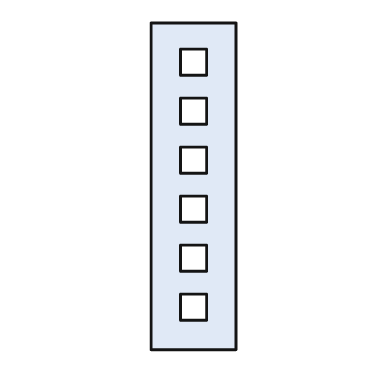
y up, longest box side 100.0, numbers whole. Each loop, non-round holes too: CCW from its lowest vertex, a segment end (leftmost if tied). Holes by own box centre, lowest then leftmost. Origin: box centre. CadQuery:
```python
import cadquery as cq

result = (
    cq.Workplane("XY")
    .moveTo(-13.0, -50.0)
    .lineTo(13.0, -50.0)
    .lineTo(13.0, 50.0)
    .lineTo(-13.0, 50.0)
    .close()
    .moveTo(-4.0, -41.0)
    .lineTo(4.0, -41.0)
    .lineTo(4.0, -33.0)
    .lineTo(-4.0, -33.0)
    .close()
    .moveTo(-4.0, -26.0)
    .lineTo(4.0, -26.0)
    .lineTo(4.0, -18.0)
    .lineTo(-4.0, -18.0)
    .close()
    .moveTo(-4.0, -11.0)
    .lineTo(4.0, -11.0)
    .lineTo(4.0, -3.0)
    .lineTo(-4.0, -3.0)
    .close()
    .moveTo(-4.0, 4.0)
    .lineTo(4.0, 4.0)
    .lineTo(4.0, 12.0)
    .lineTo(-4.0, 12.0)
    .close()
    .moveTo(-4.0, 19.0)
    .lineTo(4.0, 19.0)
    .lineTo(4.0, 27.0)
    .lineTo(-4.0, 27.0)
    .close()
    .moveTo(-4.0, 34.0)
    .lineTo(4.0, 34.0)
    .lineTo(4.0, 42.0)
    .lineTo(-4.0, 42.0)
    .close()
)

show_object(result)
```